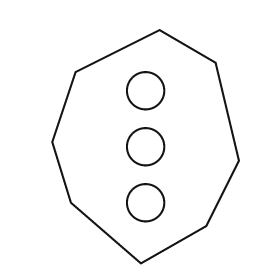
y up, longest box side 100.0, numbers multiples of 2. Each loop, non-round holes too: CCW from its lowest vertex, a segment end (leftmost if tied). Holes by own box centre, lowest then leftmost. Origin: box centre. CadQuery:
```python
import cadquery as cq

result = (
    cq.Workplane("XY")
    .moveTo(-2.0, -50.0)
    .lineTo(26.0, -34.0)
    .lineTo(40.0, -6.0)
    .lineTo(30.0, 36.0)
    .lineTo(6.0, 50.0)
    .lineTo(-30.0, 32.0)
    .lineTo(-40.0, 2.0)
    .lineTo(-32.0, -24.0)
    .close()
    .moveTo(0.0, -24.0)
    .circle(8.0)
    .moveTo(0.0, 0.0)
    .circle(8.0)
    .moveTo(0.0, 24.0)
    .circle(8.0)
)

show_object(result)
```